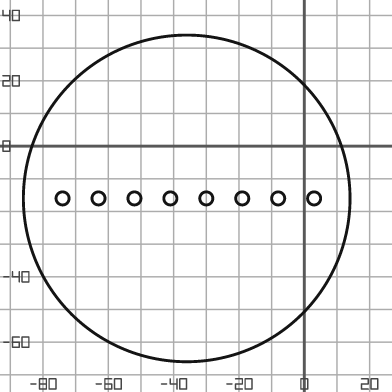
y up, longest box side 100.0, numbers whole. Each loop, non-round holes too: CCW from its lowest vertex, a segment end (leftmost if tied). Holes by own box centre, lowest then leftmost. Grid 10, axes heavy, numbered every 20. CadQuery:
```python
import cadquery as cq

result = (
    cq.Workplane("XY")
    .moveTo(-36.0, -16.0)
    .circle(50.0)
    .moveTo(-74.0, -16.0)
    .circle(2.0)
    .moveTo(-63.0, -16.0)
    .circle(2.0)
    .moveTo(-52.0, -16.0)
    .circle(2.0)
    .moveTo(-41.0, -16.0)
    .circle(2.0)
    .moveTo(-30.0, -16.0)
    .circle(2.0)
    .moveTo(-19.0, -16.0)
    .circle(2.0)
    .moveTo(-8.0, -16.0)
    .circle(2.0)
    .moveTo(3.0, -16.0)
    .circle(2.0)
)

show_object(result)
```